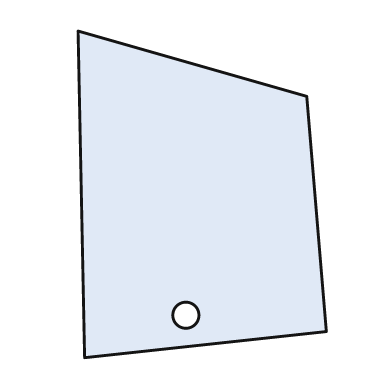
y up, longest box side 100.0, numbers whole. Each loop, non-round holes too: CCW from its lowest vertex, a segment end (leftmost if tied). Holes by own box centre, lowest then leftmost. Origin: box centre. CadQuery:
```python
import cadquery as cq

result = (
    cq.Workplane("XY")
    .moveTo(-36.0, -50.0)
    .lineTo(38.0, -42.0)
    .lineTo(32.0, 30.0)
    .lineTo(-38.0, 50.0)
    .close()
    .moveTo(-5.0, -37.0)
    .circle(4.0)
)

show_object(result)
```